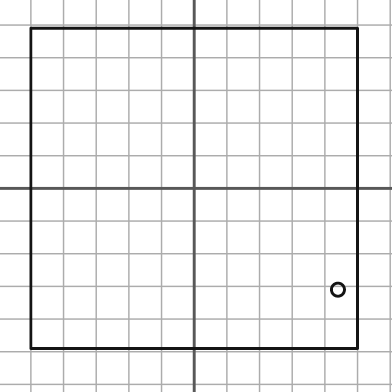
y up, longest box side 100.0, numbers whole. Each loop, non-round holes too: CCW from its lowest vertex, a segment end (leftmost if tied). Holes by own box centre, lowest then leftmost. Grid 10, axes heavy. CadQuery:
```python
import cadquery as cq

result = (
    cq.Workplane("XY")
    .moveTo(-50.0, -49.0)
    .lineTo(50.0, -49.0)
    .lineTo(50.0, 49.0)
    .lineTo(-50.0, 49.0)
    .close()
    .moveTo(44.0, -31.0)
    .circle(2.0)
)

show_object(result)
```